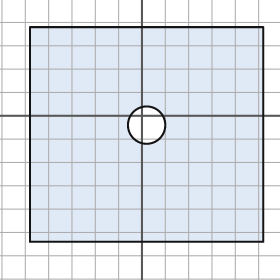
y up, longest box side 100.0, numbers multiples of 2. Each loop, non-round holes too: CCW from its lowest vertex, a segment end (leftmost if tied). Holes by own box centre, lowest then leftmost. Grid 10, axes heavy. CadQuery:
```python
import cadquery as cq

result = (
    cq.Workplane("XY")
    .moveTo(-48.0, -54.0)
    .lineTo(52.0, -54.0)
    .lineTo(52.0, 38.0)
    .lineTo(-48.0, 38.0)
    .close()
    .moveTo(2.0, -4.0)
    .circle(8.0)
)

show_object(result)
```